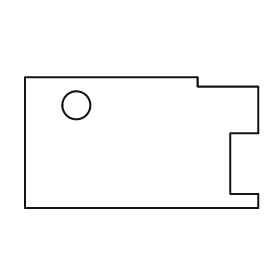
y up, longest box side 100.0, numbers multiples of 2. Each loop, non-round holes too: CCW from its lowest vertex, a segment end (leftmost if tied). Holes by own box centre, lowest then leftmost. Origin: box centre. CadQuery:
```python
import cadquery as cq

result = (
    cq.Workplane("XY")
    .moveTo(-50.0, -28.0)
    .lineTo(50.0, -28.0)
    .lineTo(50.0, -22.0)
    .lineTo(38.0, -22.0)
    .lineTo(38.0, 4.0)
    .lineTo(50.0, 4.0)
    .lineTo(50.0, 24.0)
    .lineTo(24.0, 24.0)
    .lineTo(24.0, 28.0)
    .lineTo(-50.0, 28.0)
    .close()
    .moveTo(-28.0, 16.0)
    .circle(6.0)
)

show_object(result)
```